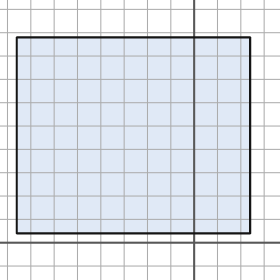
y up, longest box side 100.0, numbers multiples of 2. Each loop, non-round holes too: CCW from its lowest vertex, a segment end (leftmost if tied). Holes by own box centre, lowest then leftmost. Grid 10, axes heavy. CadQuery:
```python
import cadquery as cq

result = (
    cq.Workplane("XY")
    .moveTo(-76.0, 4.0)
    .lineTo(24.0, 4.0)
    .lineTo(24.0, 88.0)
    .lineTo(-76.0, 88.0)
    .close()
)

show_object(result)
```